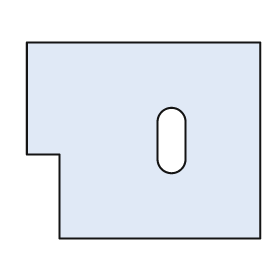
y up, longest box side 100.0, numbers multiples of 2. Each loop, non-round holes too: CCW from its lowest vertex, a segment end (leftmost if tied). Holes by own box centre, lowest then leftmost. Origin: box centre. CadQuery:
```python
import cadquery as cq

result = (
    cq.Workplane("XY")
    .moveTo(-36.0, -42.0)
    .lineTo(50.0, -42.0)
    .lineTo(50.0, 42.0)
    .lineTo(-50.0, 42.0)
    .lineTo(-50.0, -6.0)
    .lineTo(-36.0, -6.0)
    .close()
    .moveTo(6.0, -8.0)
    .threePointArc((12.0, -14.0), (18.0, -8.0))
    .lineTo(18.0, 8.0)
    .threePointArc((12.0, 14.0), (6.0, 8.0))
    .close()
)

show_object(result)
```